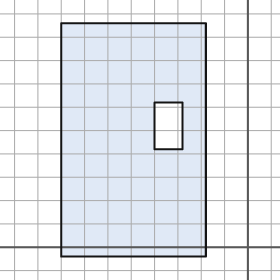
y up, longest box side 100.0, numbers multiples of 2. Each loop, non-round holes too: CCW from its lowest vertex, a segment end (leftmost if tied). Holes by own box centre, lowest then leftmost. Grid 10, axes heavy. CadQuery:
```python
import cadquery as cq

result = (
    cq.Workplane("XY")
    .moveTo(-80.0, -4.0)
    .lineTo(-18.0, -4.0)
    .lineTo(-18.0, 96.0)
    .lineTo(-80.0, 96.0)
    .close()
    .moveTo(-40.0, 42.0)
    .lineTo(-28.0, 42.0)
    .lineTo(-28.0, 62.0)
    .lineTo(-40.0, 62.0)
    .close()
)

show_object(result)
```